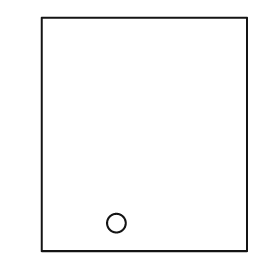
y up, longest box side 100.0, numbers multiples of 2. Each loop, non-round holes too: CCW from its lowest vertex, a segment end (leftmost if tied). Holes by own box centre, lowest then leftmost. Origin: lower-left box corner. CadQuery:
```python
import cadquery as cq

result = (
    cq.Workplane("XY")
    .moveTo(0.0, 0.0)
    .lineTo(88.0, 0.0)
    .lineTo(88.0, 100.0)
    .lineTo(0.0, 100.0)
    .close()
    .moveTo(32.0, 12.0)
    .circle(4.0)
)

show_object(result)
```